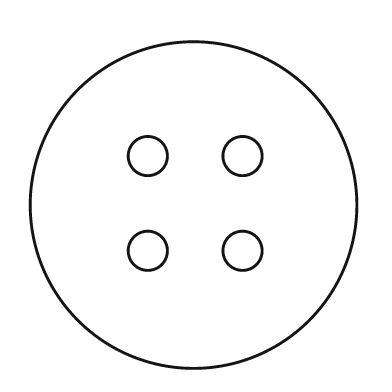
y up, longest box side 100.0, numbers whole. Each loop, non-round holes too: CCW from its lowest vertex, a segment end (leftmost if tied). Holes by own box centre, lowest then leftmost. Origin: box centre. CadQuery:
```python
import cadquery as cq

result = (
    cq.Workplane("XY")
    .moveTo(0.0, 0.0)
    .circle(50.0)
    .moveTo(-14.0, -14.0)
    .circle(6.0)
    .moveTo(15.0, -14.0)
    .circle(6.0)
    .moveTo(-14.0, 15.0)
    .circle(6.0)
    .moveTo(15.0, 15.0)
    .circle(6.0)
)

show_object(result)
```